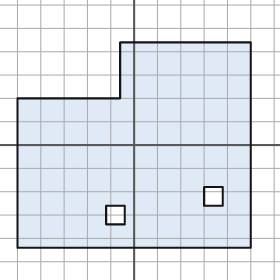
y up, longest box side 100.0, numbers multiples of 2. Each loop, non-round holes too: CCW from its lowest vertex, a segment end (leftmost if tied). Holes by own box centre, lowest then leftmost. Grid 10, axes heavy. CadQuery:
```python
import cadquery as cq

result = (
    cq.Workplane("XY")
    .moveTo(-50.0, -44.0)
    .lineTo(50.0, -44.0)
    .lineTo(50.0, 44.0)
    .lineTo(-6.0, 44.0)
    .lineTo(-6.0, 20.0)
    .lineTo(-50.0, 20.0)
    .close()
    .moveTo(-12.0, -34.0)
    .lineTo(-4.0, -34.0)
    .lineTo(-4.0, -26.0)
    .lineTo(-12.0, -26.0)
    .close()
    .moveTo(30.0, -26.0)
    .lineTo(38.0, -26.0)
    .lineTo(38.0, -18.0)
    .lineTo(30.0, -18.0)
    .close()
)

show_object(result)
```